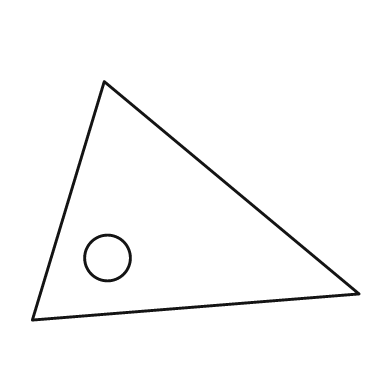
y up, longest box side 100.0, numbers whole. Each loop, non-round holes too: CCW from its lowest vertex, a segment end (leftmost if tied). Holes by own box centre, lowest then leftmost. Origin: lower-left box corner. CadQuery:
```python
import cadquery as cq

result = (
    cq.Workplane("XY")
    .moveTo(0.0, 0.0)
    .lineTo(100.0, 8.0)
    .lineTo(22.0, 73.0)
    .close()
    .moveTo(23.0, 19.0)
    .circle(7.0)
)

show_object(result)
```